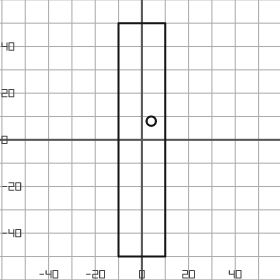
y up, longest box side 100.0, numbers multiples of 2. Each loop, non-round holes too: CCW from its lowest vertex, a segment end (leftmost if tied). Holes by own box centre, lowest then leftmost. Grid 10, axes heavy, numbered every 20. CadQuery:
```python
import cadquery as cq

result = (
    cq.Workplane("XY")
    .moveTo(-10.0, -50.0)
    .lineTo(10.0, -50.0)
    .lineTo(10.0, 50.0)
    .lineTo(-10.0, 50.0)
    .close()
    .moveTo(4.0, 8.0)
    .circle(2.0)
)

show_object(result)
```